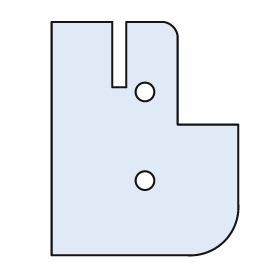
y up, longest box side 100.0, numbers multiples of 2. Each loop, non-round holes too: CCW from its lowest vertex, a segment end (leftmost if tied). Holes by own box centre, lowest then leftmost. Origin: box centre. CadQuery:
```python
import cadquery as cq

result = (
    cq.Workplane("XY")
    .moveTo(-40.0, -50.0)
    .lineTo(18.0, -50.0)
    .threePointArc((34.0, -44.0), (40.0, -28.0))
    .lineTo(40.0, 6.0)
    .lineTo(14.0, 6.0)
    .lineTo(14.0, 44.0)
    .threePointArc((12.0, 48.0), (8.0, 50.0))
    .lineTo(-8.0, 50.0)
    .lineTo(-8.0, 22.0)
    .lineTo(-14.0, 22.0)
    .lineTo(-14.0, 50.0)
    .lineTo(-40.0, 50.0)
    .close()
    .moveTo(0.0, -18.0)
    .circle(4.0)
    .moveTo(0.0, 20.0)
    .circle(4.0)
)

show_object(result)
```